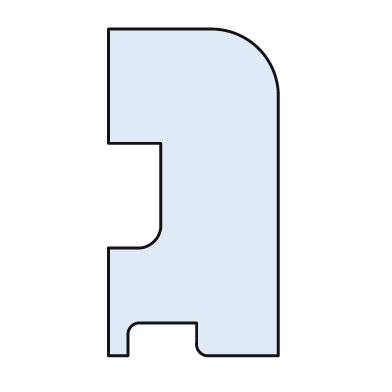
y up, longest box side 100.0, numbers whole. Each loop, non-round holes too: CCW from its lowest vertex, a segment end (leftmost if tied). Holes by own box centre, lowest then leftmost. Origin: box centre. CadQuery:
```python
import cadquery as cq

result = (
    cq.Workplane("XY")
    .moveTo(-26.0, -50.0)
    .lineTo(-20.0, -50.0)
    .lineTo(-20.0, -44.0)
    .threePointArc((-19.0, -41.0), (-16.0, -40.0))
    .lineTo(1.0, -40.0)
    .lineTo(1.0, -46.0)
    .threePointArc((2.0, -49.0), (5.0, -50.0))
    .lineTo(26.0, -50.0)
    .lineTo(26.0, 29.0)
    .threePointArc((20.0, 44.0), (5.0, 50.0))
    .lineTo(-26.0, 50.0)
    .lineTo(-26.0, 15.0)
    .lineTo(-10.0, 15.0)
    .lineTo(-10.0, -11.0)
    .threePointArc((-12.0, -15.0), (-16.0, -17.0))
    .lineTo(-26.0, -17.0)
    .close()
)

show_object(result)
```